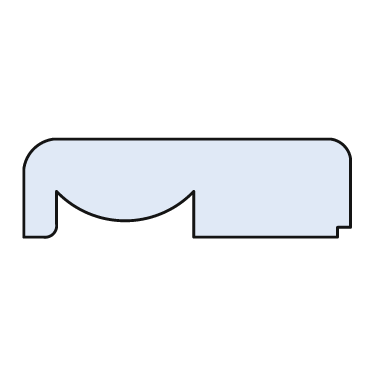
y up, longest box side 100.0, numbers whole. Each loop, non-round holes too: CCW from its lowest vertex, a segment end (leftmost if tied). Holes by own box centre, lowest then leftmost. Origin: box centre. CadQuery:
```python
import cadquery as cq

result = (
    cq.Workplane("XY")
    .moveTo(-50.0, -15.0)
    .lineTo(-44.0, -15.0)
    .threePointArc((-41.0, -14.0), (-40.0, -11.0))
    .lineTo(-40.0, -1.0)
    .threePointArc((-19.0, -10.0), (2.0, -1.0))
    .lineTo(2.0, -15.0)
    .lineTo(46.0, -15.0)
    .lineTo(46.0, -12.0)
    .lineTo(50.0, -12.0)
    .lineTo(50.0, 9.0)
    .threePointArc((48.0, 13.0), (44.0, 15.0))
    .lineTo(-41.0, 15.0)
    .threePointArc((-47.0, 12.0), (-50.0, 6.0))
    .close()
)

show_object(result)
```